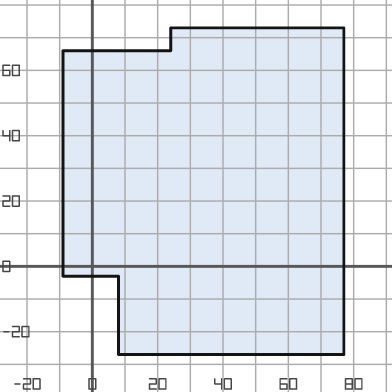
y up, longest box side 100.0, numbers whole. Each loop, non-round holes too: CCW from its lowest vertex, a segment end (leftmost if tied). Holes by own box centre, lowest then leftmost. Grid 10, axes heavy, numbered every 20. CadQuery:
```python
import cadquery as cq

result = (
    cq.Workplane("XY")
    .moveTo(8.0, -27.0)
    .lineTo(77.0, -27.0)
    .lineTo(77.0, 73.0)
    .lineTo(24.0, 73.0)
    .lineTo(24.0, 66.0)
    .lineTo(-9.0, 66.0)
    .lineTo(-9.0, -3.0)
    .lineTo(8.0, -3.0)
    .close()
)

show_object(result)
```